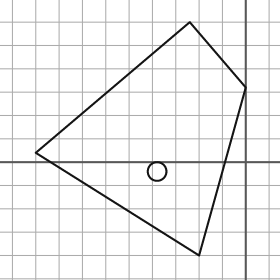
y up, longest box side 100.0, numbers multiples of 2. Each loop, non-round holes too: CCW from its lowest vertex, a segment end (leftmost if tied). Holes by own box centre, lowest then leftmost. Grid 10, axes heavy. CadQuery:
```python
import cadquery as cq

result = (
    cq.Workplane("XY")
    .moveTo(-20.0, -40.0)
    .lineTo(0.0, 32.0)
    .lineTo(-24.0, 60.0)
    .lineTo(-90.0, 4.0)
    .close()
    .moveTo(-38.0, -4.0)
    .circle(4.0)
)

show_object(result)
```